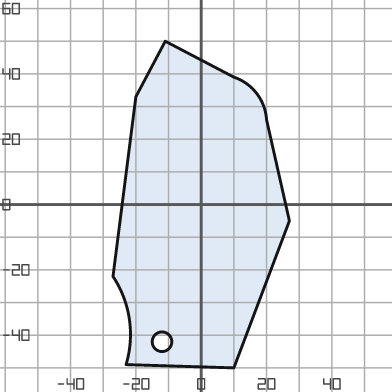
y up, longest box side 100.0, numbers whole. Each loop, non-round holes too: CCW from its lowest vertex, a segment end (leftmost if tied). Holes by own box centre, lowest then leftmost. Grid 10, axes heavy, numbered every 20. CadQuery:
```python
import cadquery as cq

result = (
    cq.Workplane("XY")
    .moveTo(10.0, -50.0)
    .lineTo(27.0, -5.0)
    .lineTo(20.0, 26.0)
    .threePointArc((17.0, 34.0), (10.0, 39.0))
    .lineTo(-11.0, 50.0)
    .lineTo(-20.0, 33.0)
    .lineTo(-27.0, -22.0)
    .threePointArc((-22.0, -35.0), (-23.0, -49.0))
    .close()
    .moveTo(-12.0, -42.0)
    .circle(3.0)
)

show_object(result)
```